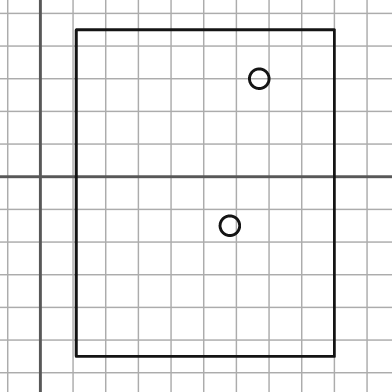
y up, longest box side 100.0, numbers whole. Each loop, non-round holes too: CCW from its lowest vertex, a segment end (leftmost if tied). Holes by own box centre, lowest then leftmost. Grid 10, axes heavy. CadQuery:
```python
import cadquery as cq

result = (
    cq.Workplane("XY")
    .moveTo(11.0, -55.0)
    .lineTo(90.0, -55.0)
    .lineTo(90.0, 45.0)
    .lineTo(11.0, 45.0)
    .close()
    .moveTo(58.0, -15.0)
    .circle(3.0)
    .moveTo(67.0, 30.0)
    .circle(3.0)
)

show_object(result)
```